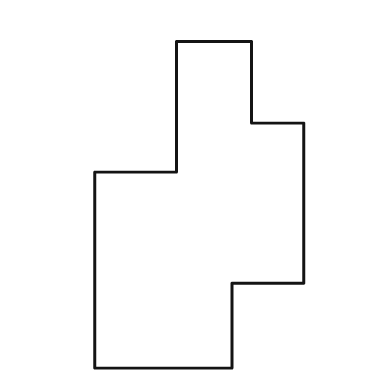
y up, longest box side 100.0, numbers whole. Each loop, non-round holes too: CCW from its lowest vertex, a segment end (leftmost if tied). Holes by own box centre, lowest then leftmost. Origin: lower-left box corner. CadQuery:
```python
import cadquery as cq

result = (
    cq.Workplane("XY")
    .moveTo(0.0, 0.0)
    .lineTo(42.0, 0.0)
    .lineTo(42.0, 26.0)
    .lineTo(64.0, 26.0)
    .lineTo(64.0, 75.0)
    .lineTo(48.0, 75.0)
    .lineTo(48.0, 100.0)
    .lineTo(25.0, 100.0)
    .lineTo(25.0, 60.0)
    .lineTo(0.0, 60.0)
    .close()
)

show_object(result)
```